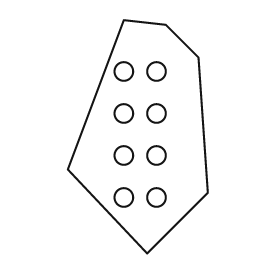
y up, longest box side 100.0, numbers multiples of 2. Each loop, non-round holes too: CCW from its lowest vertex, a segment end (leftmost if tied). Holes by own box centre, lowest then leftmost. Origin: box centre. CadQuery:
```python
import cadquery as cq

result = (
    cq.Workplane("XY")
    .moveTo(4.0, -50.0)
    .lineTo(30.0, -24.0)
    .lineTo(26.0, 34.0)
    .lineTo(12.0, 48.0)
    .lineTo(-6.0, 50.0)
    .lineTo(-30.0, -14.0)
    .close()
    .moveTo(-6.0, -26.0)
    .circle(4.0)
    .moveTo(8.0, -26.0)
    .circle(4.0)
    .moveTo(-6.0, -8.0)
    .circle(4.0)
    .moveTo(8.0, -8.0)
    .circle(4.0)
    .moveTo(-6.0, 10.0)
    .circle(4.0)
    .moveTo(8.0, 10.0)
    .circle(4.0)
    .moveTo(-6.0, 28.0)
    .circle(4.0)
    .moveTo(8.0, 28.0)
    .circle(4.0)
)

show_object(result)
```